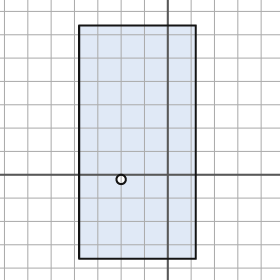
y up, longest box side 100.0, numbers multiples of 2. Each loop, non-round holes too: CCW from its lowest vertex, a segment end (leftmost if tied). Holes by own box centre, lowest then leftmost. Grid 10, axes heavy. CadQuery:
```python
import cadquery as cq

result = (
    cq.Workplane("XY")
    .moveTo(-38.0, -36.0)
    .lineTo(12.0, -36.0)
    .lineTo(12.0, 64.0)
    .lineTo(-38.0, 64.0)
    .close()
    .moveTo(-20.0, -2.0)
    .circle(2.0)
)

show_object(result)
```